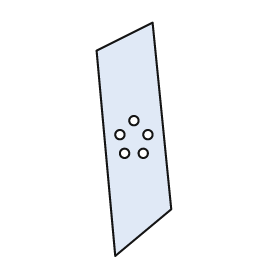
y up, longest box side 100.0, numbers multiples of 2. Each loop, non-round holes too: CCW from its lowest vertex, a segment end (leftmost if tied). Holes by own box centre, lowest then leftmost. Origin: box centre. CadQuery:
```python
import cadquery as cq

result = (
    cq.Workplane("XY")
    .moveTo(-8.0, -50.0)
    .lineTo(16.0, -30.0)
    .lineTo(8.0, 50.0)
    .lineTo(-16.0, 38.0)
    .close()
    .moveTo(-4.0, -6.0)
    .circle(2.0)
    .moveTo(4.0, -6.0)
    .circle(2.0)
    .moveTo(-6.0, 2.0)
    .circle(2.0)
    .moveTo(6.0, 2.0)
    .circle(2.0)
    .moveTo(0.0, 8.0)
    .circle(2.0)
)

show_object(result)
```